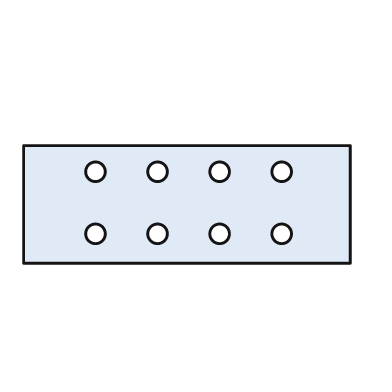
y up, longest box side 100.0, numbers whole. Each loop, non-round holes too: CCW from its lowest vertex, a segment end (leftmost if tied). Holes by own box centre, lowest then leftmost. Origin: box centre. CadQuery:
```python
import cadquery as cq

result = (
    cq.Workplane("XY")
    .moveTo(-50.0, -18.0)
    .lineTo(50.0, -18.0)
    .lineTo(50.0, 18.0)
    .lineTo(-50.0, 18.0)
    .close()
    .moveTo(-28.0, -9.0)
    .circle(3.0)
    .moveTo(-9.0, -9.0)
    .circle(3.0)
    .moveTo(10.0, -9.0)
    .circle(3.0)
    .moveTo(29.0, -9.0)
    .circle(3.0)
    .moveTo(-28.0, 10.0)
    .circle(3.0)
    .moveTo(-9.0, 10.0)
    .circle(3.0)
    .moveTo(10.0, 10.0)
    .circle(3.0)
    .moveTo(29.0, 10.0)
    .circle(3.0)
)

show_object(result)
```